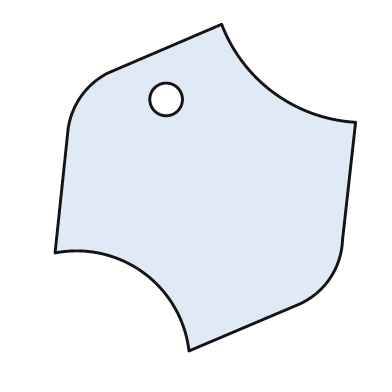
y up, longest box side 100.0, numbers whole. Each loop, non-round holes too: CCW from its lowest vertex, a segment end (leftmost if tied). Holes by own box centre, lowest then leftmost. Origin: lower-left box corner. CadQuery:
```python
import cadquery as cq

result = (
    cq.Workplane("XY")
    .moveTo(41.0, 0.0)
    .lineTo(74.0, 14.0)
    .threePointArc((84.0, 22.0), (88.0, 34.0))
    .lineTo(92.0, 70.0)
    .threePointArc((67.0, 79.0), (51.0, 100.0))
    .lineTo(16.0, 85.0)
    .threePointArc((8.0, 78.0), (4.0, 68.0))
    .lineTo(0.0, 30.0)
    .threePointArc((27.0, 24.0), (41.0, 0.0))
    .close()
    .moveTo(34.0, 77.0)
    .circle(5.0)
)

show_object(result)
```